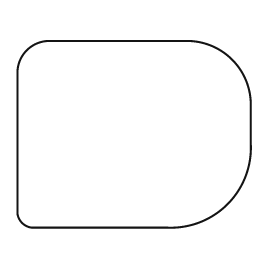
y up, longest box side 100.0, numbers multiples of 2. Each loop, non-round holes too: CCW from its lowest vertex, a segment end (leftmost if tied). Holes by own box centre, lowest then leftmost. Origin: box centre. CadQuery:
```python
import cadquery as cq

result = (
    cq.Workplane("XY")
    .moveTo(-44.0, -40.0)
    .lineTo(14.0, -40.0)
    .threePointArc((40.0, -30.0), (50.0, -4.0))
    .lineTo(50.0, 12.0)
    .threePointArc((42.0, 32.0), (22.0, 40.0))
    .lineTo(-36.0, 40.0)
    .threePointArc((-46.0, 36.0), (-50.0, 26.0))
    .lineTo(-50.0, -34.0)
    .threePointArc((-48.0, -38.0), (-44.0, -40.0))
    .close()
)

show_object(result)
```